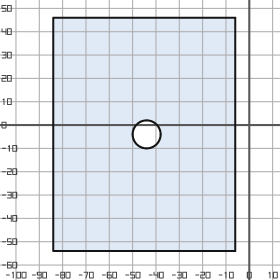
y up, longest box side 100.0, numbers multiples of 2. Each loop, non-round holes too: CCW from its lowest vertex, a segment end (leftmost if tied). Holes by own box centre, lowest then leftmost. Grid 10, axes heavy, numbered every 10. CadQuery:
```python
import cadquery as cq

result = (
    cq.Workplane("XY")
    .moveTo(-84.0, -54.0)
    .lineTo(-6.0, -54.0)
    .lineTo(-6.0, 46.0)
    .lineTo(-84.0, 46.0)
    .close()
    .moveTo(-44.0, -4.0)
    .circle(6.0)
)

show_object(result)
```